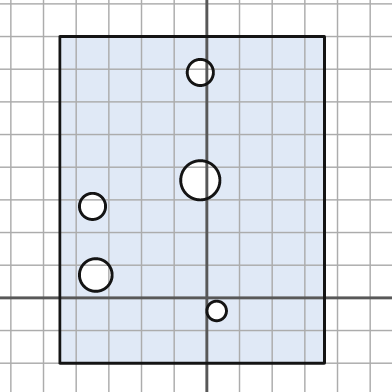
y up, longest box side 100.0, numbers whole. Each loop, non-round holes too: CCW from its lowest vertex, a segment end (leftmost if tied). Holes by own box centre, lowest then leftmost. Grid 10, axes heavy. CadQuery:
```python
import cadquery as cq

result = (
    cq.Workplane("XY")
    .moveTo(-45.0, -20.0)
    .lineTo(36.0, -20.0)
    .lineTo(36.0, 80.0)
    .lineTo(-45.0, 80.0)
    .close()
    .moveTo(3.0, -4.0)
    .circle(3.0)
    .moveTo(-34.0, 7.0)
    .circle(5.0)
    .moveTo(-35.0, 28.0)
    .circle(4.0)
    .moveTo(-2.0, 36.0)
    .circle(6.0)
    .moveTo(-2.0, 69.0)
    .circle(4.0)
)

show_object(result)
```